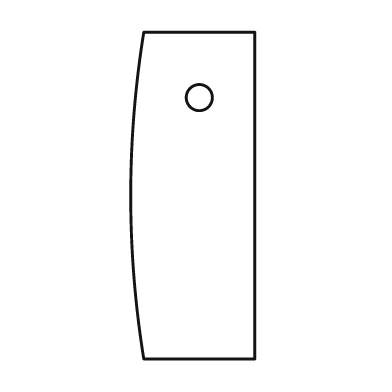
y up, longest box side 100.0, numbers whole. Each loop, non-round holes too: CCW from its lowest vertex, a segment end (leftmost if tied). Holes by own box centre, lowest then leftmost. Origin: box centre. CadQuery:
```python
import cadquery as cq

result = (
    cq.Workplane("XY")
    .moveTo(-15.0, -50.0)
    .lineTo(19.0, -50.0)
    .lineTo(19.0, 50.0)
    .lineTo(-15.0, 50.0)
    .threePointArc((-19.0, 0.0), (-15.0, -50.0))
    .close()
    .moveTo(2.0, 30.0)
    .circle(4.0)
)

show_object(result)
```